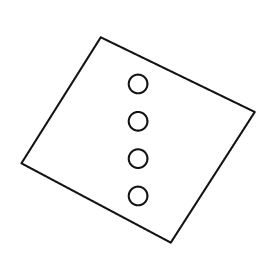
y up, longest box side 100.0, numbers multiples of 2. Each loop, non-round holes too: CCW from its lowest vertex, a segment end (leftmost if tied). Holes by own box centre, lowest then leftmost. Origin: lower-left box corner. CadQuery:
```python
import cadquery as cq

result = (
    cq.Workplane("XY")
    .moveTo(64.0, 0.0)
    .lineTo(100.0, 56.0)
    .lineTo(34.0, 88.0)
    .lineTo(0.0, 34.0)
    .close()
    .moveTo(50.0, 20.0)
    .circle(4.0)
    .moveTo(50.0, 36.0)
    .circle(4.0)
    .moveTo(50.0, 52.0)
    .circle(4.0)
    .moveTo(50.0, 68.0)
    .circle(4.0)
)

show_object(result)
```